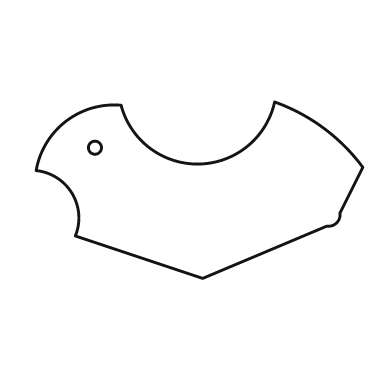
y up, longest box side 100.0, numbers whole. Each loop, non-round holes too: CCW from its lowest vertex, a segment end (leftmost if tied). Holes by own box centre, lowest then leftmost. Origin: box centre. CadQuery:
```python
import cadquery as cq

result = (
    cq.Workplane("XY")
    .moveTo(1.0, -27.0)
    .lineTo(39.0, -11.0)
    .threePointArc((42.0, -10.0), (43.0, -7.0))
    .lineTo(50.0, 7.0)
    .threePointArc((38.0, 19.0), (23.0, 27.0))
    .threePointArc((0.0, 8.0), (-24.0, 26.0))
    .threePointArc((-41.0, 21.0), (-50.0, 6.0))
    .threePointArc((-39.0, -1.0), (-38.0, -14.0))
    .close()
    .moveTo(-32.0, 13.0)
    .circle(2.0)
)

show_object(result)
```